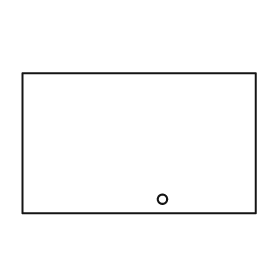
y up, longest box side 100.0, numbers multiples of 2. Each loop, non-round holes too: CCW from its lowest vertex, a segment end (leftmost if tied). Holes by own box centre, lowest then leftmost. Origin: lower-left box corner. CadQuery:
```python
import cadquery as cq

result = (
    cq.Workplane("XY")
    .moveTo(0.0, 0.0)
    .lineTo(100.0, 0.0)
    .lineTo(100.0, 60.0)
    .lineTo(0.0, 60.0)
    .close()
    .moveTo(60.0, 6.0)
    .circle(2.0)
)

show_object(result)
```